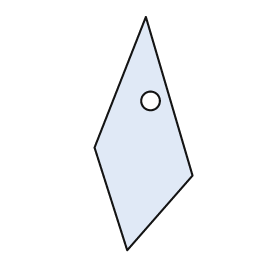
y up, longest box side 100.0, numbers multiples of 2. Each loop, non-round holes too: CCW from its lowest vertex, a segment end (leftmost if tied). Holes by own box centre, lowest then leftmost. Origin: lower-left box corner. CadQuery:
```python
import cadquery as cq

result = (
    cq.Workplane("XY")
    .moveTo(14.0, 0.0)
    .lineTo(42.0, 32.0)
    .lineTo(22.0, 100.0)
    .lineTo(0.0, 44.0)
    .close()
    .moveTo(24.0, 64.0)
    .circle(4.0)
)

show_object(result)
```